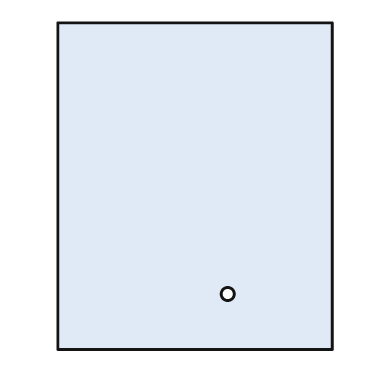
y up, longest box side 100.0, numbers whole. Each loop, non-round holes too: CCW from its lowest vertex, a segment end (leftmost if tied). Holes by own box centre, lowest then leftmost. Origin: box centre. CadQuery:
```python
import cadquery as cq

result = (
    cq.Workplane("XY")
    .moveTo(-42.0, -50.0)
    .lineTo(42.0, -50.0)
    .lineTo(42.0, 50.0)
    .lineTo(-42.0, 50.0)
    .close()
    .moveTo(10.0, -33.0)
    .circle(2.0)
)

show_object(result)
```